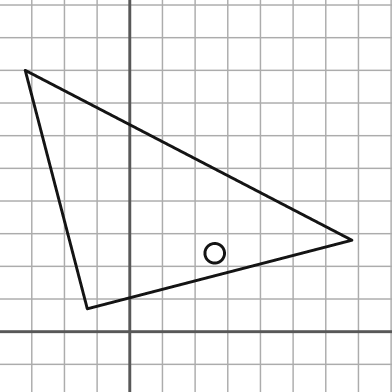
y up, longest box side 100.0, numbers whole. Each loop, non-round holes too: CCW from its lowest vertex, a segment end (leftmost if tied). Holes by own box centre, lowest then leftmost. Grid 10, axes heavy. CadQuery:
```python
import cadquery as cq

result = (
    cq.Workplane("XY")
    .moveTo(-13.0, 7.0)
    .lineTo(68.0, 28.0)
    .lineTo(-32.0, 80.0)
    .close()
    .moveTo(26.0, 24.0)
    .circle(3.0)
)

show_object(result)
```